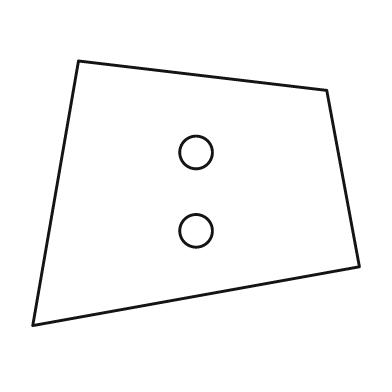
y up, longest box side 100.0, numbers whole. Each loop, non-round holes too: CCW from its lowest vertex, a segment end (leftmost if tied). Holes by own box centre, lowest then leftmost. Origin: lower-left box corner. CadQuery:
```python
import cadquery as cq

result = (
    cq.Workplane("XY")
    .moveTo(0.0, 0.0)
    .lineTo(100.0, 18.0)
    .lineTo(90.0, 72.0)
    .lineTo(14.0, 81.0)
    .close()
    .moveTo(50.0, 29.0)
    .circle(5.0)
    .moveTo(50.0, 53.0)
    .circle(5.0)
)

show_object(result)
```